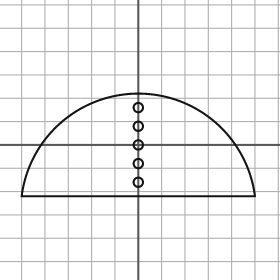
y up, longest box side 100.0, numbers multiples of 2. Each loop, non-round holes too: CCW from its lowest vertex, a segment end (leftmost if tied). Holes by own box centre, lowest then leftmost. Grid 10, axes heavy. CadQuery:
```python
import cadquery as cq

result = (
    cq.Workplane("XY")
    .moveTo(-50.0, -22.0)
    .lineTo(50.0, -22.0)
    .threePointArc((0.0, 22.0), (-50.0, -22.0))
    .close()
    .moveTo(0.0, -16.0)
    .circle(2.0)
    .moveTo(0.0, -8.0)
    .circle(2.0)
    .moveTo(0.0, 0.0)
    .circle(2.0)
    .moveTo(0.0, 8.0)
    .circle(2.0)
    .moveTo(0.0, 16.0)
    .circle(2.0)
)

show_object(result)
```